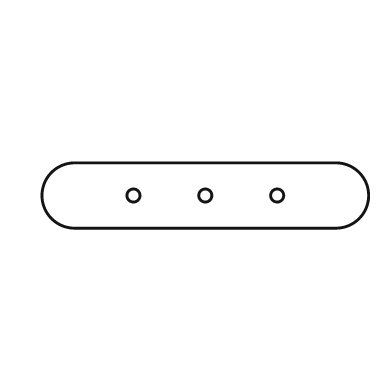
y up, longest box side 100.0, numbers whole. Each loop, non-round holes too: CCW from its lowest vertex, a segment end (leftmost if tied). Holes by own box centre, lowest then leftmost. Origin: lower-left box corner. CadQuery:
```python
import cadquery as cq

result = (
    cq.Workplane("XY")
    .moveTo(10.0, 0.0)
    .lineTo(90.0, 0.0)
    .threePointArc((100.0, 10.0), (90.0, 20.0))
    .lineTo(10.0, 20.0)
    .threePointArc((0.0, 10.0), (10.0, 0.0))
    .close()
    .moveTo(28.0, 10.0)
    .circle(2.0)
    .moveTo(50.0, 10.0)
    .circle(2.0)
    .moveTo(72.0, 10.0)
    .circle(2.0)
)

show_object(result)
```